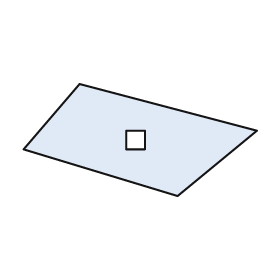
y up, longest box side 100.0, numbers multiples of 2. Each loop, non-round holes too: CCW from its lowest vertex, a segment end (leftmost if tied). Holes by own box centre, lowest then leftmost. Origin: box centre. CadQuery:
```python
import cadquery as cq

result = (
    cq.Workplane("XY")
    .moveTo(16.0, -24.0)
    .lineTo(50.0, 4.0)
    .lineTo(-26.0, 24.0)
    .lineTo(-50.0, -4.0)
    .close()
    .moveTo(-6.0, -4.0)
    .lineTo(2.0, -4.0)
    .lineTo(2.0, 4.0)
    .lineTo(-6.0, 4.0)
    .close()
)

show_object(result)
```